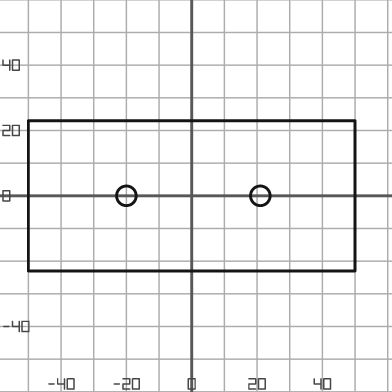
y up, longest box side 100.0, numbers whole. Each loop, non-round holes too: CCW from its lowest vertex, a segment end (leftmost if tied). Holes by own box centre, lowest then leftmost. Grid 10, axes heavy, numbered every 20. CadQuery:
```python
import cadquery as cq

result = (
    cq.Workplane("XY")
    .moveTo(-50.0, -23.0)
    .lineTo(50.0, -23.0)
    .lineTo(50.0, 23.0)
    .lineTo(-50.0, 23.0)
    .close()
    .moveTo(-20.0, 0.0)
    .circle(3.0)
    .moveTo(21.0, 0.0)
    .circle(3.0)
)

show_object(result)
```